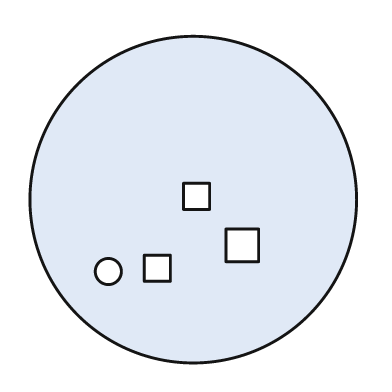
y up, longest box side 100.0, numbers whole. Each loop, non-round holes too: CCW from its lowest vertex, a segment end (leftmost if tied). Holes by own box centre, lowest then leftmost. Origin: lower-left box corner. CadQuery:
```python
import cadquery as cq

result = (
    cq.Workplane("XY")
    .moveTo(50.0, 50.0)
    .circle(50.0)
    .moveTo(24.0, 28.0)
    .circle(4.0)
    .moveTo(35.0, 25.0)
    .lineTo(43.0, 25.0)
    .lineTo(43.0, 33.0)
    .lineTo(35.0, 33.0)
    .close()
    .moveTo(60.0, 31.0)
    .lineTo(70.0, 31.0)
    .lineTo(70.0, 41.0)
    .lineTo(60.0, 41.0)
    .close()
    .moveTo(47.0, 47.0)
    .lineTo(55.0, 47.0)
    .lineTo(55.0, 55.0)
    .lineTo(47.0, 55.0)
    .close()
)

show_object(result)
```